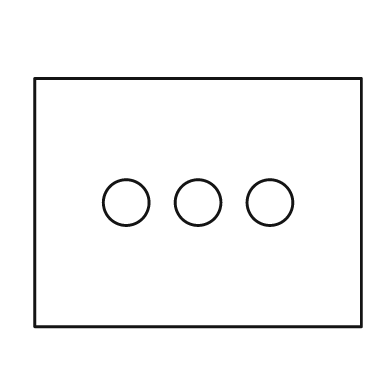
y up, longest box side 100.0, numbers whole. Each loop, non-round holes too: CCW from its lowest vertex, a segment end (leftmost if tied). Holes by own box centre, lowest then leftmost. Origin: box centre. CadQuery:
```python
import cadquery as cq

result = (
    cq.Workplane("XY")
    .moveTo(-50.0, -38.0)
    .lineTo(50.0, -38.0)
    .lineTo(50.0, 38.0)
    .lineTo(-50.0, 38.0)
    .close()
    .moveTo(-22.0, 0.0)
    .circle(7.0)
    .moveTo(0.0, 0.0)
    .circle(7.0)
    .moveTo(22.0, 0.0)
    .circle(7.0)
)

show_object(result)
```